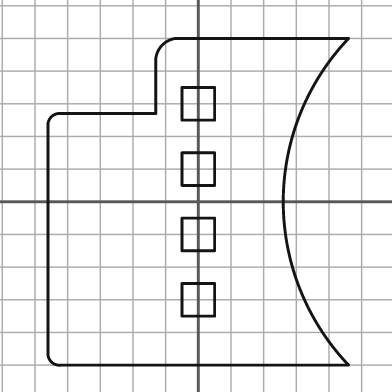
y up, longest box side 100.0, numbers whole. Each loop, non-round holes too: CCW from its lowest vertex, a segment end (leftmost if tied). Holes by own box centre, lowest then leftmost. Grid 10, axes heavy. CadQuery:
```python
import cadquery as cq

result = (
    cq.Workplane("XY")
    .moveTo(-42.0, -50.0)
    .lineTo(46.0, -50.0)
    .threePointArc((26.0, 0.0), (46.0, 50.0))
    .lineTo(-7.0, 50.0)
    .threePointArc((-11.0, 48.0), (-13.0, 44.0))
    .lineTo(-13.0, 27.0)
    .lineTo(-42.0, 27.0)
    .threePointArc((-45.0, 26.0), (-46.0, 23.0))
    .lineTo(-46.0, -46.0)
    .threePointArc((-45.0, -49.0), (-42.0, -50.0))
    .close()
    .moveTo(-5.0, -35.0)
    .lineTo(5.0, -35.0)
    .lineTo(5.0, -25.0)
    .lineTo(-5.0, -25.0)
    .close()
    .moveTo(-5.0, -15.0)
    .lineTo(5.0, -15.0)
    .lineTo(5.0, -5.0)
    .lineTo(-5.0, -5.0)
    .close()
    .moveTo(-5.0, 5.0)
    .lineTo(5.0, 5.0)
    .lineTo(5.0, 15.0)
    .lineTo(-5.0, 15.0)
    .close()
    .moveTo(-5.0, 25.0)
    .lineTo(5.0, 25.0)
    .lineTo(5.0, 35.0)
    .lineTo(-5.0, 35.0)
    .close()
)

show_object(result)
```